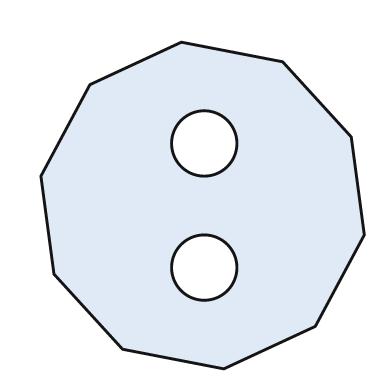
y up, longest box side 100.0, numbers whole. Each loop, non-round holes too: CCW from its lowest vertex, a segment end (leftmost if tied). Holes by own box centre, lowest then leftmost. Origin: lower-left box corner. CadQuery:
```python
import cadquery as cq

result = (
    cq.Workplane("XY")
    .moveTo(56.0, 0.0)
    .lineTo(84.0, 13.0)
    .lineTo(99.0, 41.0)
    .lineTo(95.0, 71.0)
    .lineTo(74.0, 94.0)
    .lineTo(43.0, 100.0)
    .lineTo(15.0, 87.0)
    .lineTo(0.0, 59.0)
    .lineTo(4.0, 29.0)
    .lineTo(25.0, 6.0)
    .close()
    .moveTo(50.0, 31.0)
    .circle(10.0)
    .moveTo(50.0, 69.0)
    .circle(10.0)
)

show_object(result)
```